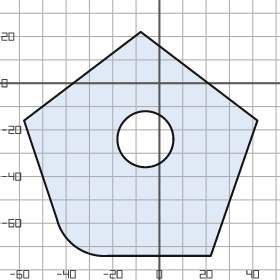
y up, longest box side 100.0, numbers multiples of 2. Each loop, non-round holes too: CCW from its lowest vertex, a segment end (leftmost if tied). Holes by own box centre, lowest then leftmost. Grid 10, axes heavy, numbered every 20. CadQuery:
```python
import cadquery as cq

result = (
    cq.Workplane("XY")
    .moveTo(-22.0, -74.0)
    .lineTo(22.0, -74.0)
    .lineTo(42.0, -16.0)
    .lineTo(-8.0, 22.0)
    .lineTo(-58.0, -16.0)
    .lineTo(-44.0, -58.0)
    .threePointArc((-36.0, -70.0), (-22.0, -74.0))
    .close()
    .moveTo(-6.0, -24.0)
    .circle(12.0)
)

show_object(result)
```